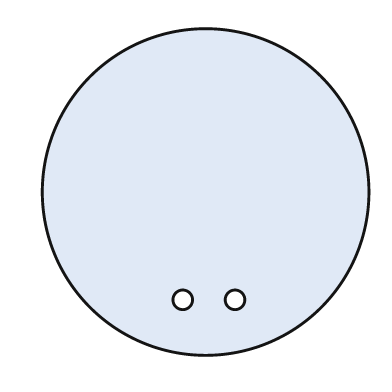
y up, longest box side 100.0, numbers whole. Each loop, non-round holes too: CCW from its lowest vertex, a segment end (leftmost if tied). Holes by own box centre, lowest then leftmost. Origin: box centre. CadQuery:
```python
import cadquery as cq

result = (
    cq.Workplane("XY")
    .moveTo(0.0, 0.0)
    .circle(50.0)
    .moveTo(-7.0, -33.0)
    .circle(3.0)
    .moveTo(9.0, -33.0)
    .circle(3.0)
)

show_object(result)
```